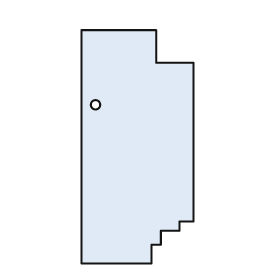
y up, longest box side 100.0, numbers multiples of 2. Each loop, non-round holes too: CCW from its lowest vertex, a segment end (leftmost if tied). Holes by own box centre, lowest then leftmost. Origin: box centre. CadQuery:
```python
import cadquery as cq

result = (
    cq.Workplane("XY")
    .moveTo(-24.0, -50.0)
    .lineTo(6.0, -50.0)
    .lineTo(6.0, -42.0)
    .lineTo(10.0, -42.0)
    .lineTo(10.0, -36.0)
    .lineTo(18.0, -36.0)
    .lineTo(18.0, -32.0)
    .lineTo(24.0, -32.0)
    .lineTo(24.0, 36.0)
    .lineTo(8.0, 36.0)
    .lineTo(8.0, 50.0)
    .lineTo(-24.0, 50.0)
    .close()
    .moveTo(-18.0, 18.0)
    .circle(2.0)
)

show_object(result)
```